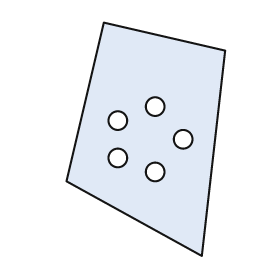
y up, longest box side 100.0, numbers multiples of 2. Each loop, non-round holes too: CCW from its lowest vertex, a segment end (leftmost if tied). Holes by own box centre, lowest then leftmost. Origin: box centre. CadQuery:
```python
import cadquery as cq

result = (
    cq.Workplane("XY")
    .moveTo(24.0, -50.0)
    .lineTo(34.0, 38.0)
    .lineTo(-18.0, 50.0)
    .lineTo(-34.0, -18.0)
    .close()
    .moveTo(4.0, -14.0)
    .circle(4.0)
    .moveTo(-12.0, -8.0)
    .circle(4.0)
    .moveTo(16.0, 0.0)
    .circle(4.0)
    .moveTo(-12.0, 8.0)
    .circle(4.0)
    .moveTo(4.0, 14.0)
    .circle(4.0)
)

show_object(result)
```